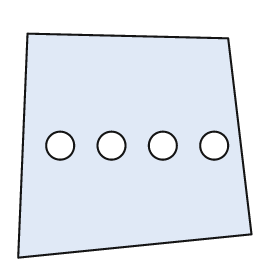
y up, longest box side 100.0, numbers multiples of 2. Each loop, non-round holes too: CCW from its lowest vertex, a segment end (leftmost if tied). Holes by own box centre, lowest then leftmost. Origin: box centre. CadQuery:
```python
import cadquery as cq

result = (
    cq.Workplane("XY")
    .moveTo(-50.0, -48.0)
    .lineTo(50.0, -38.0)
    .lineTo(40.0, 46.0)
    .lineTo(-46.0, 48.0)
    .close()
    .moveTo(-32.0, 0.0)
    .circle(6.0)
    .moveTo(-10.0, 0.0)
    .circle(6.0)
    .moveTo(12.0, 0.0)
    .circle(6.0)
    .moveTo(34.0, 0.0)
    .circle(6.0)
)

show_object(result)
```